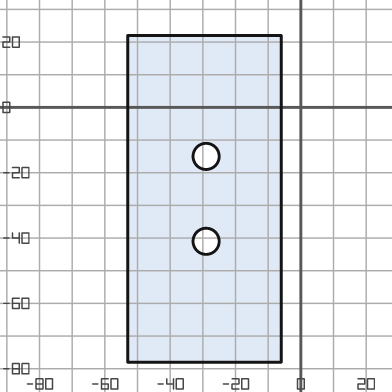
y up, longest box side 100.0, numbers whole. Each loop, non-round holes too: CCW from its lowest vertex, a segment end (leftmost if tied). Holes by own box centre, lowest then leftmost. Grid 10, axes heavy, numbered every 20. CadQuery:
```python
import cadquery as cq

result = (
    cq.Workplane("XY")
    .moveTo(-53.0, -78.0)
    .lineTo(-6.0, -78.0)
    .lineTo(-6.0, 22.0)
    .lineTo(-53.0, 22.0)
    .close()
    .moveTo(-29.0, -41.0)
    .circle(4.0)
    .moveTo(-29.0, -15.0)
    .circle(4.0)
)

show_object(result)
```